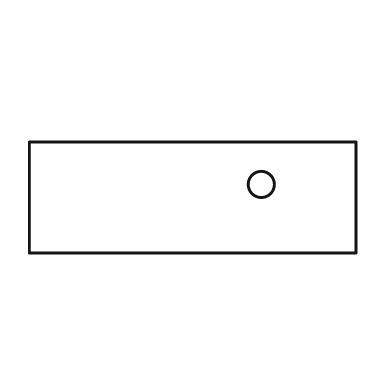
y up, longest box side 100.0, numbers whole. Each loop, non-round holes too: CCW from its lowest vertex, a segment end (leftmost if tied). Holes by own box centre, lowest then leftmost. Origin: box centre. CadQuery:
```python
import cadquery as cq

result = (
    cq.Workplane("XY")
    .moveTo(-50.0, -17.0)
    .lineTo(50.0, -17.0)
    .lineTo(50.0, 17.0)
    .lineTo(-50.0, 17.0)
    .close()
    .moveTo(21.0, 4.0)
    .circle(4.0)
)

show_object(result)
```